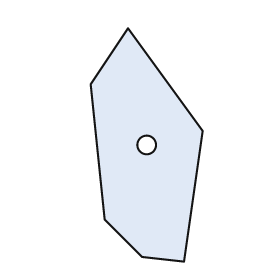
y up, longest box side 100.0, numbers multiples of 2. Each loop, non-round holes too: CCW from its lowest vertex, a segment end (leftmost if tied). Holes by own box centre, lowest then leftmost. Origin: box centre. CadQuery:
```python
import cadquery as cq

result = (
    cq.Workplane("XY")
    .moveTo(16.0, -50.0)
    .lineTo(24.0, 6.0)
    .lineTo(-8.0, 50.0)
    .lineTo(-24.0, 26.0)
    .lineTo(-18.0, -32.0)
    .lineTo(-2.0, -48.0)
    .close()
    .moveTo(0.0, 0.0)
    .circle(4.0)
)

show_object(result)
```